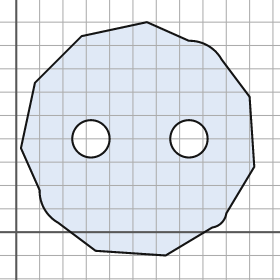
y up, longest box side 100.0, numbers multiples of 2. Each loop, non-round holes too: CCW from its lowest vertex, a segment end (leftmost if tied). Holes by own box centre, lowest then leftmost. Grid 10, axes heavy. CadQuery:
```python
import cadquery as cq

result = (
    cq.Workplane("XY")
    .moveTo(64.0, -10.0)
    .lineTo(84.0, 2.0)
    .threePointArc((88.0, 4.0), (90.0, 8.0))
    .lineTo(102.0, 28.0)
    .lineTo(100.0, 58.0)
    .lineTo(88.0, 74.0)
    .threePointArc((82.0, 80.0), (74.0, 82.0))
    .lineTo(56.0, 90.0)
    .lineTo(28.0, 84.0)
    .lineTo(8.0, 64.0)
    .lineTo(2.0, 36.0)
    .lineTo(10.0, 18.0)
    .threePointArc((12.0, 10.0), (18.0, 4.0))
    .lineTo(34.0, -8.0)
    .close()
    .moveTo(32.0, 40.0)
    .circle(8.0)
    .moveTo(74.0, 40.0)
    .circle(8.0)
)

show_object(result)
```